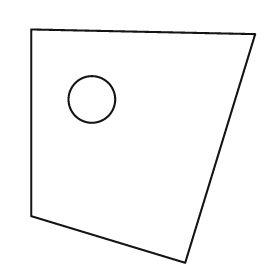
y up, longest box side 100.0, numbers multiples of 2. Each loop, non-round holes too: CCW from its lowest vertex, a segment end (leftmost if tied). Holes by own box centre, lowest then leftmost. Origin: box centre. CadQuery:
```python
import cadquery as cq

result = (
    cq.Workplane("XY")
    .moveTo(18.0, -50.0)
    .lineTo(48.0, 48.0)
    .lineTo(-48.0, 50.0)
    .lineTo(-48.0, -30.0)
    .close()
    .moveTo(-22.0, 20.0)
    .circle(10.0)
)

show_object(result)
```